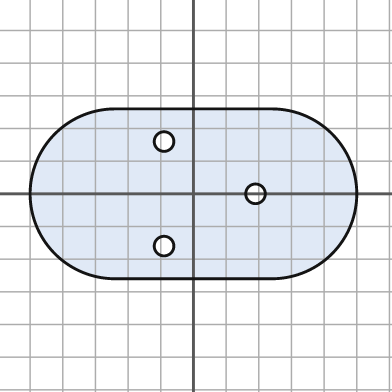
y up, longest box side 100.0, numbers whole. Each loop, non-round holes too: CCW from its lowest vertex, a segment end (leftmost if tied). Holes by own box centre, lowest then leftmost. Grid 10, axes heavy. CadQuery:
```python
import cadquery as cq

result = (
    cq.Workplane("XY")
    .moveTo(-24.0, -26.0)
    .lineTo(24.0, -26.0)
    .threePointArc((50.0, 0.0), (24.0, 26.0))
    .lineTo(-24.0, 26.0)
    .threePointArc((-50.0, 0.0), (-24.0, -26.0))
    .close()
    .moveTo(-9.0, -16.0)
    .circle(3.0)
    .moveTo(19.0, 0.0)
    .circle(3.0)
    .moveTo(-9.0, 16.0)
    .circle(3.0)
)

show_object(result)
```